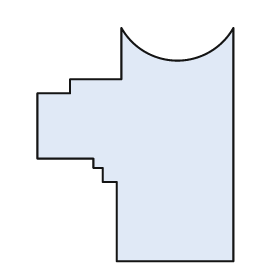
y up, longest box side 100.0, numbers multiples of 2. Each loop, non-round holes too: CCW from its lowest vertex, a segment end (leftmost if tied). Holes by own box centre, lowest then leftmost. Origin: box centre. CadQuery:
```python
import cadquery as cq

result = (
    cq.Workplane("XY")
    .moveTo(-8.0, -50.0)
    .lineTo(42.0, -50.0)
    .lineTo(42.0, 50.0)
    .threePointArc((18.0, 36.0), (-6.0, 50.0))
    .lineTo(-6.0, 28.0)
    .lineTo(-28.0, 28.0)
    .lineTo(-28.0, 22.0)
    .lineTo(-42.0, 22.0)
    .lineTo(-42.0, -6.0)
    .lineTo(-18.0, -6.0)
    .lineTo(-18.0, -10.0)
    .lineTo(-14.0, -10.0)
    .lineTo(-14.0, -16.0)
    .lineTo(-8.0, -16.0)
    .close()
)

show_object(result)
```